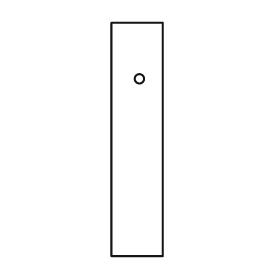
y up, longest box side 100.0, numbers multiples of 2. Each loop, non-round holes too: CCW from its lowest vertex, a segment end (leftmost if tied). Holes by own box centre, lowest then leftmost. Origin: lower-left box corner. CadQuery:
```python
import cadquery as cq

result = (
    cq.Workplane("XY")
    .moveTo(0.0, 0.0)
    .lineTo(22.0, 0.0)
    .lineTo(22.0, 100.0)
    .lineTo(0.0, 100.0)
    .close()
    .moveTo(12.0, 76.0)
    .circle(2.0)
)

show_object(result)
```